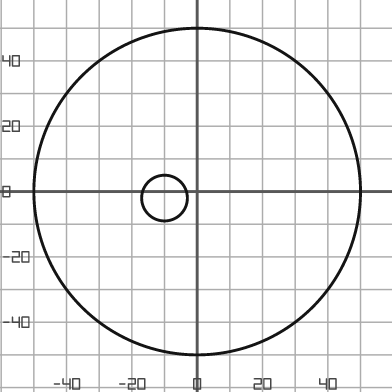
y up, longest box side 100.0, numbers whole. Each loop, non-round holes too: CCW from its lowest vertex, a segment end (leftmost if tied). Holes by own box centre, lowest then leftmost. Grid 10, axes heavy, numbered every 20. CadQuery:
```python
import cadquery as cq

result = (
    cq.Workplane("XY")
    .moveTo(0.0, 0.0)
    .circle(50.0)
    .moveTo(-10.0, -2.0)
    .circle(7.0)
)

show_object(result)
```